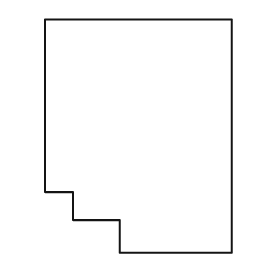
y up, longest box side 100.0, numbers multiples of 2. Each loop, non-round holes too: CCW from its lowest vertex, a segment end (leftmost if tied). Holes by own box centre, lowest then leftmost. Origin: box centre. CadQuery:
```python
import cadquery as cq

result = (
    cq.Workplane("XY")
    .moveTo(-8.0, -50.0)
    .lineTo(40.0, -50.0)
    .lineTo(40.0, 50.0)
    .lineTo(-40.0, 50.0)
    .lineTo(-40.0, -24.0)
    .lineTo(-28.0, -24.0)
    .lineTo(-28.0, -36.0)
    .lineTo(-8.0, -36.0)
    .close()
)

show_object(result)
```